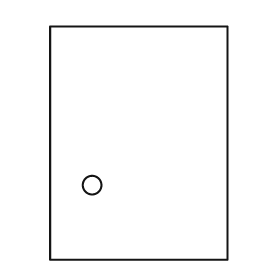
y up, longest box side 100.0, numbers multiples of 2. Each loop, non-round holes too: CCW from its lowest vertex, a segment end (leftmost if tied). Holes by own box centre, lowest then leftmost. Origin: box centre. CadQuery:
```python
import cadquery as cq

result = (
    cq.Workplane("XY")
    .moveTo(-38.0, -50.0)
    .lineTo(38.0, -50.0)
    .lineTo(38.0, 50.0)
    .lineTo(-38.0, 50.0)
    .close()
    .moveTo(-20.0, -18.0)
    .circle(4.0)
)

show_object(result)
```